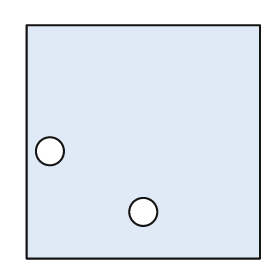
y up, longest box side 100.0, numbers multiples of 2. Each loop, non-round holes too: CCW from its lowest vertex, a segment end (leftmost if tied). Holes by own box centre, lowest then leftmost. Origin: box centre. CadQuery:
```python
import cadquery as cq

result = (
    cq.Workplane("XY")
    .moveTo(-50.0, -50.0)
    .lineTo(50.0, -50.0)
    .lineTo(50.0, 50.0)
    .lineTo(-50.0, 50.0)
    .close()
    .moveTo(0.0, -30.0)
    .circle(6.0)
    .moveTo(-40.0, -4.0)
    .circle(6.0)
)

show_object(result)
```